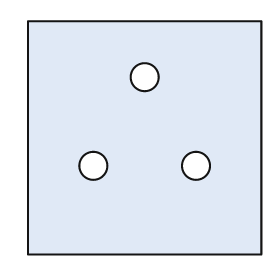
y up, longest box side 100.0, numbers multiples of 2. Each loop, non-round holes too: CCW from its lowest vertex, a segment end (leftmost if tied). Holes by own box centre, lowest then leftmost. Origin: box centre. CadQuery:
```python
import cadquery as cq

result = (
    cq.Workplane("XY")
    .moveTo(-50.0, -50.0)
    .lineTo(50.0, -50.0)
    .lineTo(50.0, 50.0)
    .lineTo(-50.0, 50.0)
    .close()
    .moveTo(-22.0, -12.0)
    .circle(6.0)
    .moveTo(22.0, -12.0)
    .circle(6.0)
    .moveTo(0.0, 26.0)
    .circle(6.0)
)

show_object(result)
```